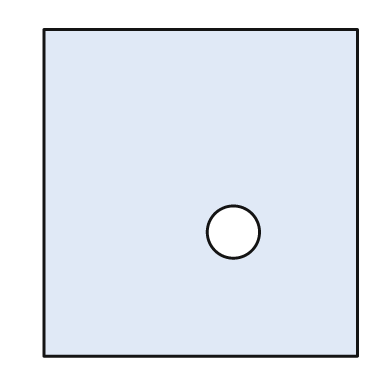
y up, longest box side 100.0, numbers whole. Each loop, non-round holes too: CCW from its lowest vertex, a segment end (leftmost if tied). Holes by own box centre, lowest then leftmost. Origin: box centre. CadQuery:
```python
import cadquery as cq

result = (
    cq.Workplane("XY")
    .moveTo(-48.0, -50.0)
    .lineTo(48.0, -50.0)
    .lineTo(48.0, 50.0)
    .lineTo(-48.0, 50.0)
    .close()
    .moveTo(10.0, -12.0)
    .circle(8.0)
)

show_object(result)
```